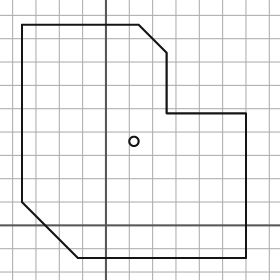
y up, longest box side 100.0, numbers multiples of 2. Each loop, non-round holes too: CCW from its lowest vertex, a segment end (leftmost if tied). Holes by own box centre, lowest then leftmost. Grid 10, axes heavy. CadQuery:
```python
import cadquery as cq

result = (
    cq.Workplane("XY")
    .moveTo(-12.0, -14.0)
    .lineTo(60.0, -14.0)
    .lineTo(60.0, 48.0)
    .lineTo(26.0, 48.0)
    .lineTo(26.0, 74.0)
    .lineTo(14.0, 86.0)
    .lineTo(-36.0, 86.0)
    .lineTo(-36.0, 10.0)
    .close()
    .moveTo(12.0, 36.0)
    .circle(2.0)
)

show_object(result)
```